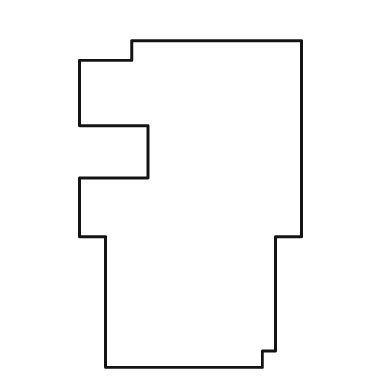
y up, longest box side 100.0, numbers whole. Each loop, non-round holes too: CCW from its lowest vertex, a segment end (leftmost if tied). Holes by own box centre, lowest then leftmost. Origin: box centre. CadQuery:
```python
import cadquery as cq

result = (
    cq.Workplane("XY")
    .moveTo(-26.0, -50.0)
    .lineTo(22.0, -50.0)
    .lineTo(22.0, -45.0)
    .lineTo(26.0, -45.0)
    .lineTo(26.0, -10.0)
    .lineTo(34.0, -10.0)
    .lineTo(34.0, 50.0)
    .lineTo(-18.0, 50.0)
    .lineTo(-18.0, 44.0)
    .lineTo(-34.0, 44.0)
    .lineTo(-34.0, 24.0)
    .lineTo(-13.0, 24.0)
    .lineTo(-13.0, 8.0)
    .lineTo(-34.0, 8.0)
    .lineTo(-34.0, -10.0)
    .lineTo(-26.0, -10.0)
    .close()
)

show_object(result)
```